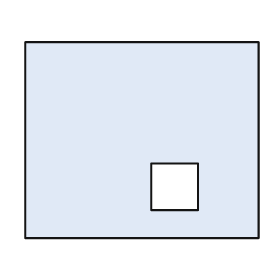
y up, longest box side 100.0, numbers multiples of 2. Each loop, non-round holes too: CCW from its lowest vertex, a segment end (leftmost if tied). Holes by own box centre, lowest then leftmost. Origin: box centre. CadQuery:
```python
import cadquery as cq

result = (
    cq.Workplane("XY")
    .moveTo(-50.0, -42.0)
    .lineTo(50.0, -42.0)
    .lineTo(50.0, 42.0)
    .lineTo(-50.0, 42.0)
    .close()
    .moveTo(4.0, -30.0)
    .lineTo(24.0, -30.0)
    .lineTo(24.0, -10.0)
    .lineTo(4.0, -10.0)
    .close()
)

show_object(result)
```